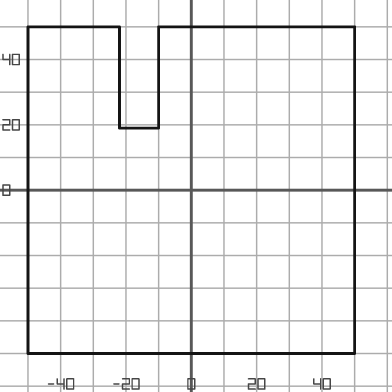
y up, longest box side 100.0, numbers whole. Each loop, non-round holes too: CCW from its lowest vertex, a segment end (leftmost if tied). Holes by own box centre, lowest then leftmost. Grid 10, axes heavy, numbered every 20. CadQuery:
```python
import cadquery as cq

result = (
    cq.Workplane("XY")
    .moveTo(-50.0, -50.0)
    .lineTo(50.0, -50.0)
    .lineTo(50.0, 50.0)
    .lineTo(-10.0, 50.0)
    .lineTo(-10.0, 19.0)
    .lineTo(-22.0, 19.0)
    .lineTo(-22.0, 50.0)
    .lineTo(-50.0, 50.0)
    .close()
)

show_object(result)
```